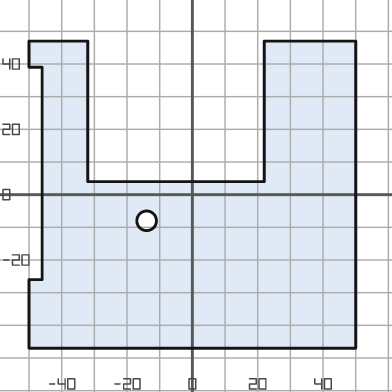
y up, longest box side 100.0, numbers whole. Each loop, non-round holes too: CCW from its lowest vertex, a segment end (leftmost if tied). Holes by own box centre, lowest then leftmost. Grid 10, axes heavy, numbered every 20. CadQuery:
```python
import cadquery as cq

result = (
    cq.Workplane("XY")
    .moveTo(-50.0, -47.0)
    .lineTo(50.0, -47.0)
    .lineTo(50.0, 47.0)
    .lineTo(22.0, 47.0)
    .lineTo(22.0, 4.0)
    .lineTo(-32.0, 4.0)
    .lineTo(-32.0, 47.0)
    .lineTo(-50.0, 47.0)
    .lineTo(-50.0, 39.0)
    .lineTo(-46.0, 39.0)
    .lineTo(-46.0, -26.0)
    .lineTo(-50.0, -26.0)
    .close()
    .moveTo(-14.0, -8.0)
    .circle(3.0)
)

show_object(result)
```